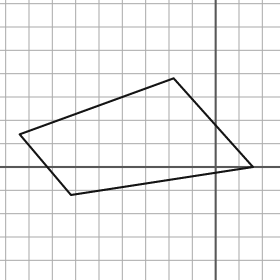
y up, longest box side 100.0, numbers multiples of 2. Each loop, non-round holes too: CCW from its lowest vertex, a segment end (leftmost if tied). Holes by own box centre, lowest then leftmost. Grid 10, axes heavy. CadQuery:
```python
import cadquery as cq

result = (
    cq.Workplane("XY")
    .moveTo(-62.0, -12.0)
    .lineTo(16.0, 0.0)
    .lineTo(-18.0, 38.0)
    .lineTo(-84.0, 14.0)
    .close()
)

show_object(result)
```